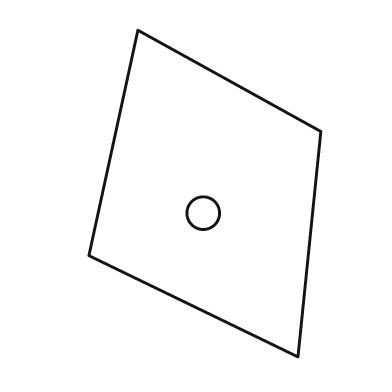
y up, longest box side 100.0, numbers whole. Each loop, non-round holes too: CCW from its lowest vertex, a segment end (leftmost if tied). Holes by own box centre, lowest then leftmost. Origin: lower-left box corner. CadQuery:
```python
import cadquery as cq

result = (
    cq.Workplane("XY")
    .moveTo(64.0, 0.0)
    .lineTo(71.0, 69.0)
    .lineTo(15.0, 100.0)
    .lineTo(0.0, 31.0)
    .close()
    .moveTo(35.0, 44.0)
    .circle(5.0)
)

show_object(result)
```